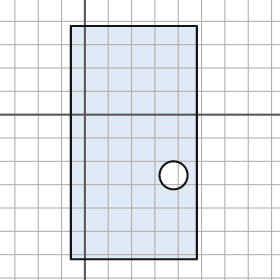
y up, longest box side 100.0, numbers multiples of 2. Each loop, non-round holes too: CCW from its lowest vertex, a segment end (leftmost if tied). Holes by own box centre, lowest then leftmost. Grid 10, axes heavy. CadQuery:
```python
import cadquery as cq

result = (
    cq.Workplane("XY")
    .moveTo(-6.0, -62.0)
    .lineTo(48.0, -62.0)
    .lineTo(48.0, 38.0)
    .lineTo(-6.0, 38.0)
    .close()
    .moveTo(38.0, -26.0)
    .circle(6.0)
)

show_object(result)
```